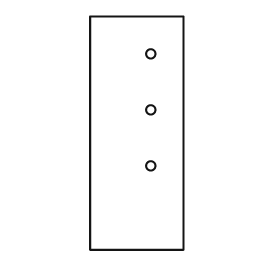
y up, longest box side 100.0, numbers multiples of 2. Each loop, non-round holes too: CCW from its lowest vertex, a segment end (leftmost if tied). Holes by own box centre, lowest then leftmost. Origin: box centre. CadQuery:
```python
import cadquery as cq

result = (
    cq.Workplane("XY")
    .moveTo(-20.0, -50.0)
    .lineTo(20.0, -50.0)
    .lineTo(20.0, 50.0)
    .lineTo(-20.0, 50.0)
    .close()
    .moveTo(6.0, -14.0)
    .circle(2.0)
    .moveTo(6.0, 10.0)
    .circle(2.0)
    .moveTo(6.0, 34.0)
    .circle(2.0)
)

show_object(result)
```